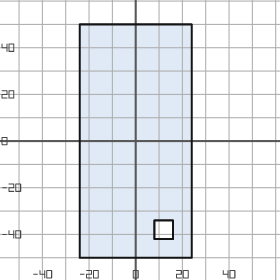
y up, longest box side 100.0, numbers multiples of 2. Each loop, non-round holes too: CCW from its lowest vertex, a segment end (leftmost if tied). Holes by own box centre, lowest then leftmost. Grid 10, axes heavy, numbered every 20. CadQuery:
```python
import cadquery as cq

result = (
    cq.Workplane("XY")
    .moveTo(-24.0, -50.0)
    .lineTo(24.0, -50.0)
    .lineTo(24.0, 50.0)
    .lineTo(-24.0, 50.0)
    .close()
    .moveTo(8.0, -42.0)
    .lineTo(16.0, -42.0)
    .lineTo(16.0, -34.0)
    .lineTo(8.0, -34.0)
    .close()
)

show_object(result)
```